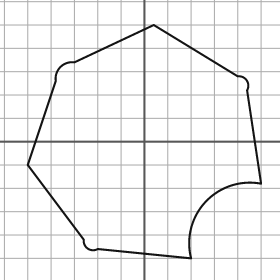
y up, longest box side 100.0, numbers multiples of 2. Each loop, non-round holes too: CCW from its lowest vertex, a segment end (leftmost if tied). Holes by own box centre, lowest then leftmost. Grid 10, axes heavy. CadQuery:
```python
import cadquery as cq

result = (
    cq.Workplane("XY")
    .moveTo(20.0, -50.0)
    .threePointArc((26.0, -26.0), (50.0, -18.0))
    .lineTo(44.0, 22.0)
    .threePointArc((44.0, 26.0), (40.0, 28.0))
    .lineTo(4.0, 50.0)
    .lineTo(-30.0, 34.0)
    .threePointArc((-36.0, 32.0), (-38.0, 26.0))
    .lineTo(-50.0, -10.0)
    .lineTo(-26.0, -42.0)
    .threePointArc((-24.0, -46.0), (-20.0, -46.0))
    .close()
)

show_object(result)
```